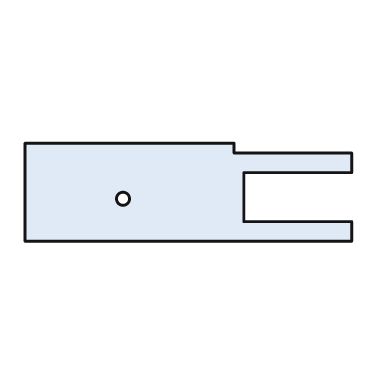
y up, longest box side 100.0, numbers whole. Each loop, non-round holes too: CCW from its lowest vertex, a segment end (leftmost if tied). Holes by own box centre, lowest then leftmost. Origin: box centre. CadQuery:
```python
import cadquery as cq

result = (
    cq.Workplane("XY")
    .moveTo(-50.0, -15.0)
    .lineTo(50.0, -15.0)
    .lineTo(50.0, -9.0)
    .lineTo(17.0, -9.0)
    .lineTo(17.0, 6.0)
    .lineTo(50.0, 6.0)
    .lineTo(50.0, 12.0)
    .lineTo(14.0, 12.0)
    .lineTo(14.0, 15.0)
    .lineTo(-50.0, 15.0)
    .close()
    .moveTo(-20.0, -2.0)
    .circle(2.0)
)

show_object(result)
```